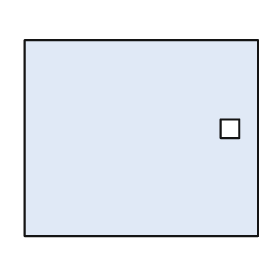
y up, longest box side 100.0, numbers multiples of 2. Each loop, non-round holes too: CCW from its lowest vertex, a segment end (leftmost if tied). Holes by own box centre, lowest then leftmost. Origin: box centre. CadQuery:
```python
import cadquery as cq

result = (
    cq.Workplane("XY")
    .moveTo(-50.0, -42.0)
    .lineTo(50.0, -42.0)
    .lineTo(50.0, 42.0)
    .lineTo(-50.0, 42.0)
    .close()
    .moveTo(34.0, 0.0)
    .lineTo(42.0, 0.0)
    .lineTo(42.0, 8.0)
    .lineTo(34.0, 8.0)
    .close()
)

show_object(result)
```